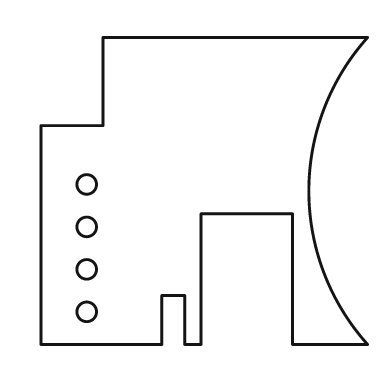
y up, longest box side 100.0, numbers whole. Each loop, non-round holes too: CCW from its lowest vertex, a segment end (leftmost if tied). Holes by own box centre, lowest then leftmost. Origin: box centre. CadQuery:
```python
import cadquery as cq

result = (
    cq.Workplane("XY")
    .moveTo(-50.0, -47.0)
    .lineTo(-13.0, -47.0)
    .lineTo(-13.0, -32.0)
    .lineTo(-6.0, -32.0)
    .lineTo(-6.0, -47.0)
    .lineTo(-1.0, -47.0)
    .lineTo(-1.0, -7.0)
    .lineTo(27.0, -7.0)
    .lineTo(27.0, -47.0)
    .lineTo(50.0, -47.0)
    .threePointArc((32.0, 0.0), (50.0, 47.0))
    .lineTo(-31.0, 47.0)
    .lineTo(-31.0, 20.0)
    .lineTo(-50.0, 20.0)
    .close()
    .moveTo(-36.0, -37.0)
    .circle(3.0)
    .moveTo(-36.0, -24.0)
    .circle(3.0)
    .moveTo(-36.0, -11.0)
    .circle(3.0)
    .moveTo(-36.0, 2.0)
    .circle(3.0)
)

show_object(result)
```